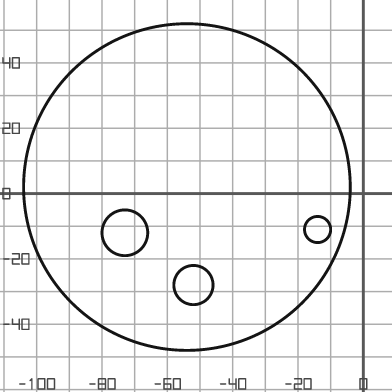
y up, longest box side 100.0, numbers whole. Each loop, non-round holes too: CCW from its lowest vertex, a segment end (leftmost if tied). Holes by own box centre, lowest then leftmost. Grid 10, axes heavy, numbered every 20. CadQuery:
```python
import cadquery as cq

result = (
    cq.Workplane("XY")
    .moveTo(-54.0, 2.0)
    .circle(50.0)
    .moveTo(-52.0, -28.0)
    .circle(6.0)
    .moveTo(-73.0, -12.0)
    .circle(7.0)
    .moveTo(-14.0, -11.0)
    .circle(4.0)
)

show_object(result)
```